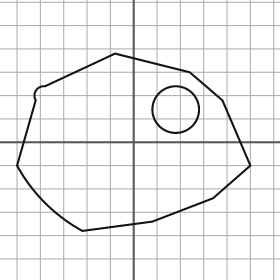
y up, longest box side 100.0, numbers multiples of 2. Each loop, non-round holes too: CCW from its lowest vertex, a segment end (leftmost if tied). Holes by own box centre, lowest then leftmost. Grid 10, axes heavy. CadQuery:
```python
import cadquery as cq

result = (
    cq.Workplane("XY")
    .moveTo(-22.0, -38.0)
    .lineTo(8.0, -34.0)
    .lineTo(34.0, -24.0)
    .lineTo(50.0, -10.0)
    .lineTo(38.0, 18.0)
    .lineTo(24.0, 30.0)
    .lineTo(-8.0, 38.0)
    .lineTo(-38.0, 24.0)
    .threePointArc((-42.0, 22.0), (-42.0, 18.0))
    .lineTo(-50.0, -10.0)
    .threePointArc((-38.0, -26.0), (-22.0, -38.0))
    .close()
    .moveTo(18.0, 14.0)
    .circle(10.0)
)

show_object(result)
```